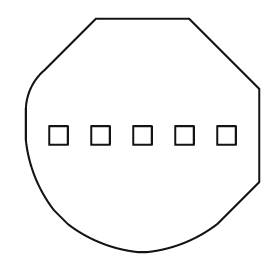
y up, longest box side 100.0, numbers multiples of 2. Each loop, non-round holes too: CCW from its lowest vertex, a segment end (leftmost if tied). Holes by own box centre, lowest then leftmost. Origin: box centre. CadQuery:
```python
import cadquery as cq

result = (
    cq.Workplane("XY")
    .moveTo(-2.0, -50.0)
    .lineTo(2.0, -50.0)
    .threePointArc((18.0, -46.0), (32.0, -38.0))
    .lineTo(50.0, -20.0)
    .lineTo(50.0, 20.0)
    .lineTo(20.0, 50.0)
    .lineTo(-20.0, 50.0)
    .lineTo(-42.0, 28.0)
    .threePointArc((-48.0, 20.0), (-50.0, 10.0))
    .lineTo(-50.0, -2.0)
    .threePointArc((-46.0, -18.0), (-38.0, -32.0))
    .lineTo(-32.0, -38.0)
    .threePointArc((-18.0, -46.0), (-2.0, -50.0))
    .close()
    .moveTo(-40.0, -4.0)
    .lineTo(-32.0, -4.0)
    .lineTo(-32.0, 4.0)
    .lineTo(-40.0, 4.0)
    .close()
    .moveTo(-22.0, -4.0)
    .lineTo(-14.0, -4.0)
    .lineTo(-14.0, 4.0)
    .lineTo(-22.0, 4.0)
    .close()
    .moveTo(-4.0, -4.0)
    .lineTo(4.0, -4.0)
    .lineTo(4.0, 4.0)
    .lineTo(-4.0, 4.0)
    .close()
    .moveTo(14.0, -4.0)
    .lineTo(22.0, -4.0)
    .lineTo(22.0, 4.0)
    .lineTo(14.0, 4.0)
    .close()
    .moveTo(32.0, -4.0)
    .lineTo(40.0, -4.0)
    .lineTo(40.0, 4.0)
    .lineTo(32.0, 4.0)
    .close()
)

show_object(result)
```